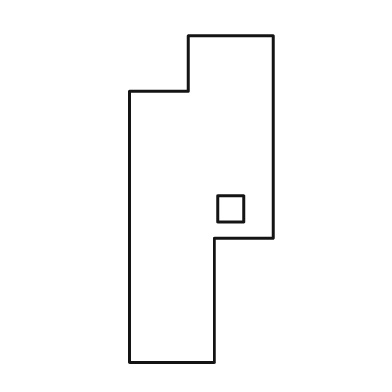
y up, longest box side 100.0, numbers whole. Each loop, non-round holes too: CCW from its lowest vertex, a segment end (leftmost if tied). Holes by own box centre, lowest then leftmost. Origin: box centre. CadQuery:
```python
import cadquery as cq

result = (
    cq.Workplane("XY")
    .moveTo(-22.0, -50.0)
    .lineTo(4.0, -50.0)
    .lineTo(4.0, -12.0)
    .lineTo(22.0, -12.0)
    .lineTo(22.0, 50.0)
    .lineTo(-4.0, 50.0)
    .lineTo(-4.0, 33.0)
    .lineTo(-22.0, 33.0)
    .close()
    .moveTo(5.0, -7.0)
    .lineTo(13.0, -7.0)
    .lineTo(13.0, 1.0)
    .lineTo(5.0, 1.0)
    .close()
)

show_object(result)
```